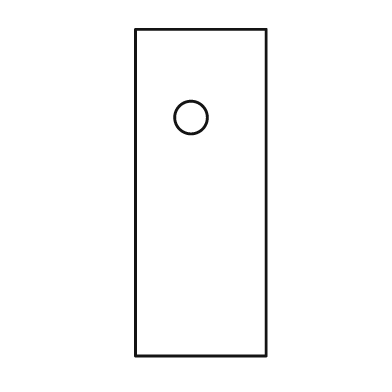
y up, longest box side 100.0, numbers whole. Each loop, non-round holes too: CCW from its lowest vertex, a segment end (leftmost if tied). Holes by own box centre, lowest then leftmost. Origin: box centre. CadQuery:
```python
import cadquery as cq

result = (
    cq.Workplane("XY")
    .moveTo(-20.0, -50.0)
    .lineTo(20.0, -50.0)
    .lineTo(20.0, 50.0)
    .lineTo(-20.0, 50.0)
    .close()
    .moveTo(-3.0, 23.0)
    .circle(5.0)
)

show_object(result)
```